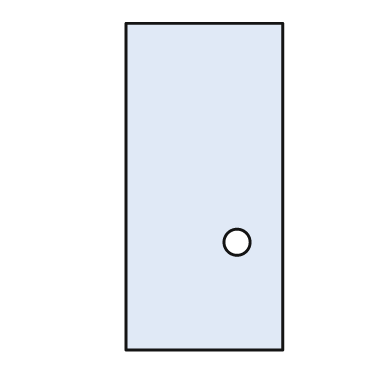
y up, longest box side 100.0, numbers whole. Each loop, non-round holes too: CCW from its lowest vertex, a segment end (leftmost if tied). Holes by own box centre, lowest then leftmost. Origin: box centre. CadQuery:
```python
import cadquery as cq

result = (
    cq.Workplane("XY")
    .moveTo(-24.0, -50.0)
    .lineTo(24.0, -50.0)
    .lineTo(24.0, 50.0)
    .lineTo(-24.0, 50.0)
    .close()
    .moveTo(10.0, -17.0)
    .circle(4.0)
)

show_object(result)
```